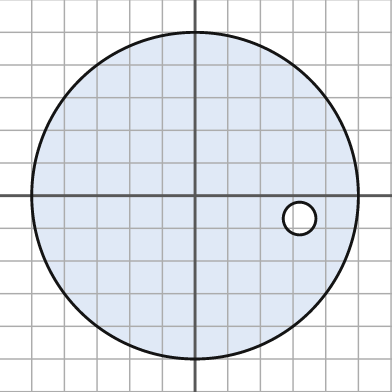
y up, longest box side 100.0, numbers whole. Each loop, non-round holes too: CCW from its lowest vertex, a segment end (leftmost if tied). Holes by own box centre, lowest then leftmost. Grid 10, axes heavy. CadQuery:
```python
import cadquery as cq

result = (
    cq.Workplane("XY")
    .moveTo(0.0, 0.0)
    .circle(50.0)
    .moveTo(32.0, -7.0)
    .circle(5.0)
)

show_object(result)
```